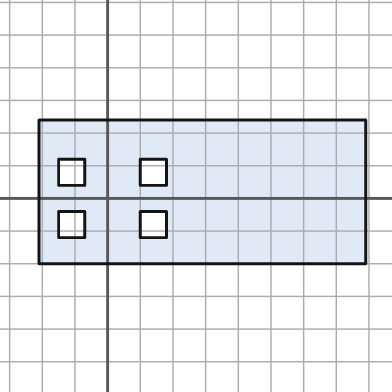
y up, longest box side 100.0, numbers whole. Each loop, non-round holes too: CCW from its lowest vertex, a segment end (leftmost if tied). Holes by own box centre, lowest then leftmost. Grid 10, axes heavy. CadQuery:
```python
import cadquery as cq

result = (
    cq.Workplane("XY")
    .moveTo(-21.0, -20.0)
    .lineTo(79.0, -20.0)
    .lineTo(79.0, 24.0)
    .lineTo(-21.0, 24.0)
    .close()
    .moveTo(-15.0, -12.0)
    .lineTo(-7.0, -12.0)
    .lineTo(-7.0, -4.0)
    .lineTo(-15.0, -4.0)
    .close()
    .moveTo(10.0, -12.0)
    .lineTo(18.0, -12.0)
    .lineTo(18.0, -4.0)
    .lineTo(10.0, -4.0)
    .close()
    .moveTo(-15.0, 4.0)
    .lineTo(-7.0, 4.0)
    .lineTo(-7.0, 12.0)
    .lineTo(-15.0, 12.0)
    .close()
    .moveTo(10.0, 4.0)
    .lineTo(18.0, 4.0)
    .lineTo(18.0, 12.0)
    .lineTo(10.0, 12.0)
    .close()
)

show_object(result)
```